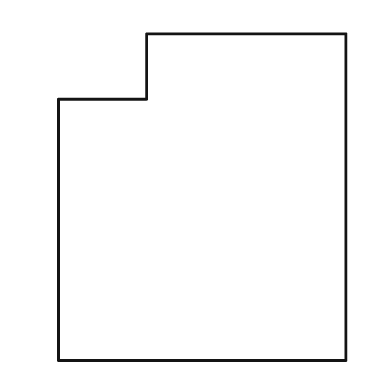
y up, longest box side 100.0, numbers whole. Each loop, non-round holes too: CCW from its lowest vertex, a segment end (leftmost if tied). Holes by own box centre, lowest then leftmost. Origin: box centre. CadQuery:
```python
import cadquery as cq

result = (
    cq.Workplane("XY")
    .moveTo(-44.0, -50.0)
    .lineTo(44.0, -50.0)
    .lineTo(44.0, 50.0)
    .lineTo(-17.0, 50.0)
    .lineTo(-17.0, 30.0)
    .lineTo(-44.0, 30.0)
    .close()
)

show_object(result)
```